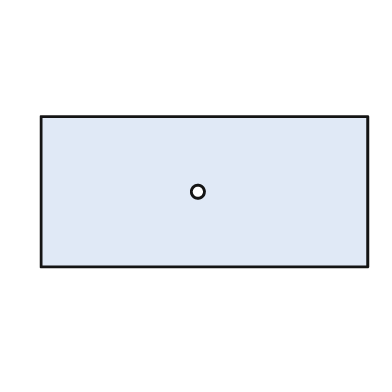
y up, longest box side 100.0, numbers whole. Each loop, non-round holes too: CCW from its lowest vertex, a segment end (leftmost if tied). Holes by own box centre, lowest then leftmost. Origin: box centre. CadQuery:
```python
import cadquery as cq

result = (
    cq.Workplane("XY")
    .moveTo(-50.0, -23.0)
    .lineTo(50.0, -23.0)
    .lineTo(50.0, 23.0)
    .lineTo(-50.0, 23.0)
    .close()
    .moveTo(-2.0, 0.0)
    .circle(2.0)
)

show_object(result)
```